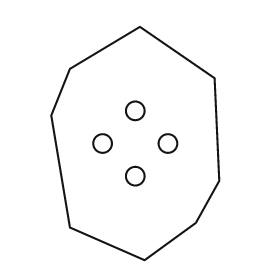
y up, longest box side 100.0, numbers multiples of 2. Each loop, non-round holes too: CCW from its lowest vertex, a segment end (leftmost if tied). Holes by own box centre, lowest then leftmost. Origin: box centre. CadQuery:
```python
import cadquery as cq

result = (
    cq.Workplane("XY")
    .moveTo(4.0, -50.0)
    .lineTo(26.0, -34.0)
    .lineTo(36.0, -16.0)
    .lineTo(34.0, 28.0)
    .lineTo(2.0, 50.0)
    .lineTo(-28.0, 32.0)
    .lineTo(-36.0, 12.0)
    .lineTo(-28.0, -36.0)
    .close()
    .moveTo(0.0, -14.0)
    .circle(4.0)
    .moveTo(-14.0, 0.0)
    .circle(4.0)
    .moveTo(14.0, 0.0)
    .circle(4.0)
    .moveTo(0.0, 14.0)
    .circle(4.0)
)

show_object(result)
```